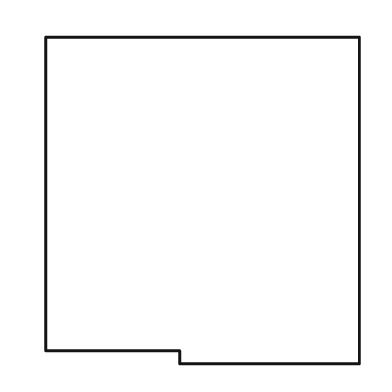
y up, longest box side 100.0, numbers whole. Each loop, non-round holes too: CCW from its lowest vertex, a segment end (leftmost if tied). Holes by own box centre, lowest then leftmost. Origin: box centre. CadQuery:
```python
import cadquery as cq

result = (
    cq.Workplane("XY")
    .moveTo(-7.0, -50.0)
    .lineTo(48.0, -50.0)
    .lineTo(48.0, 50.0)
    .lineTo(-48.0, 50.0)
    .lineTo(-48.0, -46.0)
    .lineTo(-7.0, -46.0)
    .close()
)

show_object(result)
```